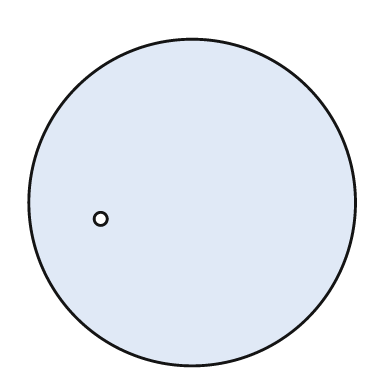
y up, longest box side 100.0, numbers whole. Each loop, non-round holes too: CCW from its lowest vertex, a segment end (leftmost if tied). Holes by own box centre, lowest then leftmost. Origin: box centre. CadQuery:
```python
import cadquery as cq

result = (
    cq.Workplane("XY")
    .moveTo(0.0, 0.0)
    .circle(50.0)
    .moveTo(-28.0, -5.0)
    .circle(2.0)
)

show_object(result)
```